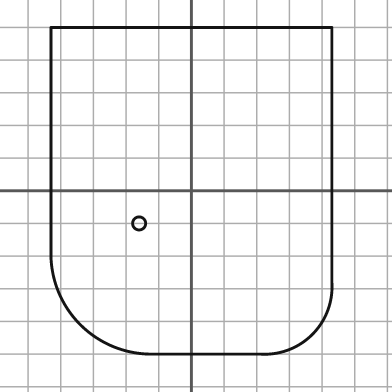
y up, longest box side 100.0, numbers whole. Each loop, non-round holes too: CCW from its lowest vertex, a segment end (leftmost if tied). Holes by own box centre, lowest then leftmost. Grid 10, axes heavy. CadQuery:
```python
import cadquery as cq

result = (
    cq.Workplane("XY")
    .moveTo(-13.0, -50.0)
    .lineTo(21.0, -50.0)
    .threePointArc((37.0, -44.0), (43.0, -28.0))
    .lineTo(43.0, 50.0)
    .lineTo(-43.0, 50.0)
    .lineTo(-43.0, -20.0)
    .threePointArc((-34.0, -41.0), (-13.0, -50.0))
    .close()
    .moveTo(-16.0, -10.0)
    .circle(2.0)
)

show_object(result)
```